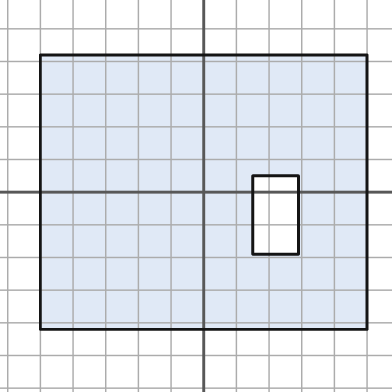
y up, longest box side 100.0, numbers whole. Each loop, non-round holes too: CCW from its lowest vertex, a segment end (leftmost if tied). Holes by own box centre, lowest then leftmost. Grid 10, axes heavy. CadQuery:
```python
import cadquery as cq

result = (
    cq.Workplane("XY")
    .moveTo(-50.0, -42.0)
    .lineTo(50.0, -42.0)
    .lineTo(50.0, 42.0)
    .lineTo(-50.0, 42.0)
    .close()
    .moveTo(15.0, -19.0)
    .lineTo(29.0, -19.0)
    .lineTo(29.0, 5.0)
    .lineTo(15.0, 5.0)
    .close()
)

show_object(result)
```